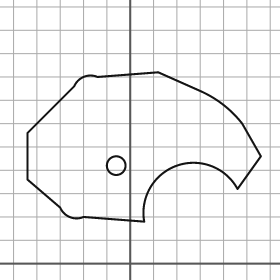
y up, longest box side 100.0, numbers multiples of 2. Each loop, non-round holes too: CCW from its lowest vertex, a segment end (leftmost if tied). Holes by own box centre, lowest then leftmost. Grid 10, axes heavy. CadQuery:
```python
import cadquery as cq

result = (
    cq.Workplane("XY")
    .moveTo(6.0, 18.0)
    .threePointArc((20.0, 42.0), (46.0, 32.0))
    .lineTo(56.0, 46.0)
    .lineTo(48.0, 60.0)
    .threePointArc((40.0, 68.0), (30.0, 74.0))
    .lineTo(12.0, 82.0)
    .lineTo(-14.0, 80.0)
    .threePointArc((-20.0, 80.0), (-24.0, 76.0))
    .lineTo(-44.0, 56.0)
    .lineTo(-44.0, 36.0)
    .lineTo(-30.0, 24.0)
    .threePointArc((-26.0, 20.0), (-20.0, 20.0))
    .close()
    .moveTo(-6.0, 42.0)
    .circle(4.0)
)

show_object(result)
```